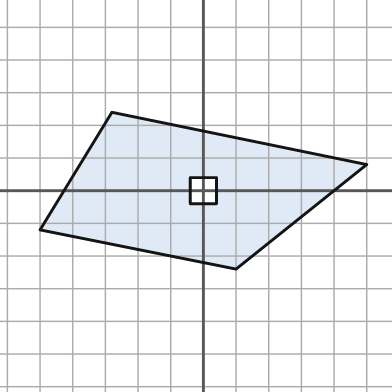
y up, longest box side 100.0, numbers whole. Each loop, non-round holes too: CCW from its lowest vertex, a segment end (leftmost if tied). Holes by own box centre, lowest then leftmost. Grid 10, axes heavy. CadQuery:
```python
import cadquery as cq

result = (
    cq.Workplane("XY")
    .moveTo(10.0, -24.0)
    .lineTo(50.0, 8.0)
    .lineTo(-28.0, 24.0)
    .lineTo(-50.0, -12.0)
    .close()
    .moveTo(-4.0, -4.0)
    .lineTo(4.0, -4.0)
    .lineTo(4.0, 4.0)
    .lineTo(-4.0, 4.0)
    .close()
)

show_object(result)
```